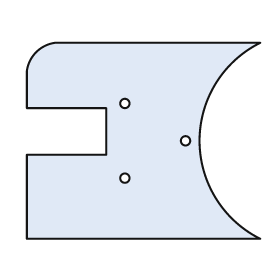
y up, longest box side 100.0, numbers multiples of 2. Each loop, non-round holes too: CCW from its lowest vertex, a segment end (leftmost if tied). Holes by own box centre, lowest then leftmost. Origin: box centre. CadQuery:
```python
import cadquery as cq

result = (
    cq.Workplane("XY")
    .moveTo(-50.0, -42.0)
    .lineTo(50.0, -42.0)
    .threePointArc((24.0, 0.0), (50.0, 42.0))
    .lineTo(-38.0, 42.0)
    .threePointArc((-46.0, 38.0), (-50.0, 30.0))
    .lineTo(-50.0, 14.0)
    .lineTo(-16.0, 14.0)
    .lineTo(-16.0, -6.0)
    .lineTo(-50.0, -6.0)
    .close()
    .moveTo(-8.0, -16.0)
    .circle(2.0)
    .moveTo(18.0, 0.0)
    .circle(2.0)
    .moveTo(-8.0, 16.0)
    .circle(2.0)
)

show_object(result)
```